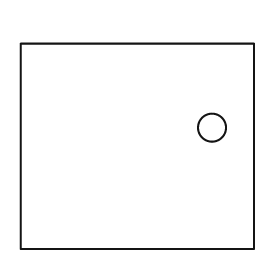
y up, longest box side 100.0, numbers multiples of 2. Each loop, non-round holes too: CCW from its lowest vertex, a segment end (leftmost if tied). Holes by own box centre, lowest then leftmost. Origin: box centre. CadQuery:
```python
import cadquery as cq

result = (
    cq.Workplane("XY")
    .moveTo(-50.0, -44.0)
    .lineTo(50.0, -44.0)
    .lineTo(50.0, 44.0)
    .lineTo(-50.0, 44.0)
    .close()
    .moveTo(32.0, 8.0)
    .circle(6.0)
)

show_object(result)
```